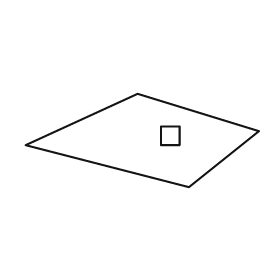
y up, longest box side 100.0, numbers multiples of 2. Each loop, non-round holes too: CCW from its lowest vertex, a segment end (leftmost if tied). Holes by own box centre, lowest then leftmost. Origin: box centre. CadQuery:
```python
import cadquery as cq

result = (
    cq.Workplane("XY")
    .moveTo(20.0, -20.0)
    .lineTo(50.0, 4.0)
    .lineTo(-2.0, 20.0)
    .lineTo(-50.0, -2.0)
    .close()
    .moveTo(8.0, -2.0)
    .lineTo(16.0, -2.0)
    .lineTo(16.0, 6.0)
    .lineTo(8.0, 6.0)
    .close()
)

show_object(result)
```